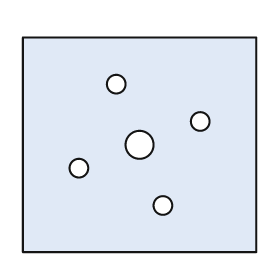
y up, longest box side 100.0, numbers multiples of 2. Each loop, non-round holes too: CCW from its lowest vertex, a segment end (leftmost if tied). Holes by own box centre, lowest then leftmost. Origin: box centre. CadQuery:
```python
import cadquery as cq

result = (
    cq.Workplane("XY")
    .moveTo(-50.0, -46.0)
    .lineTo(50.0, -46.0)
    .lineTo(50.0, 46.0)
    .lineTo(-50.0, 46.0)
    .close()
    .moveTo(10.0, -26.0)
    .circle(4.0)
    .moveTo(-26.0, -10.0)
    .circle(4.0)
    .moveTo(0.0, 0.0)
    .circle(6.0)
    .moveTo(26.0, 10.0)
    .circle(4.0)
    .moveTo(-10.0, 26.0)
    .circle(4.0)
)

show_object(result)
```